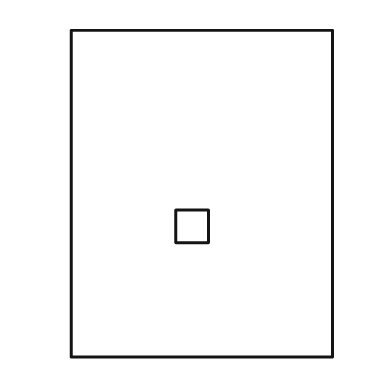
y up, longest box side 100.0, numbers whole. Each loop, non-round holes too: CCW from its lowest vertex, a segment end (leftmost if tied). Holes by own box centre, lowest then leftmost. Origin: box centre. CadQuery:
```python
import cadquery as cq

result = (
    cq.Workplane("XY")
    .moveTo(-40.0, -50.0)
    .lineTo(40.0, -50.0)
    .lineTo(40.0, 50.0)
    .lineTo(-40.0, 50.0)
    .close()
    .moveTo(-8.0, -15.0)
    .lineTo(2.0, -15.0)
    .lineTo(2.0, -5.0)
    .lineTo(-8.0, -5.0)
    .close()
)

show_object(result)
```